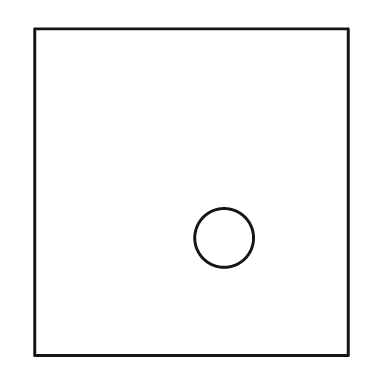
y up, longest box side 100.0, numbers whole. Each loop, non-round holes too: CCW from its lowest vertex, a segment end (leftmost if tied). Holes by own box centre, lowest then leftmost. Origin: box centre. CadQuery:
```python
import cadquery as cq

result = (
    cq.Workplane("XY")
    .moveTo(-48.0, -50.0)
    .lineTo(48.0, -50.0)
    .lineTo(48.0, 50.0)
    .lineTo(-48.0, 50.0)
    .close()
    .moveTo(10.0, -14.0)
    .circle(9.0)
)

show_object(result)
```